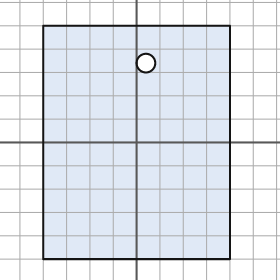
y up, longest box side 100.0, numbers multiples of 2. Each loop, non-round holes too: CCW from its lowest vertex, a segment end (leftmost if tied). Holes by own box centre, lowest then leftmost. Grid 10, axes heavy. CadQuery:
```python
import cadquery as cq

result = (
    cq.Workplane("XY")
    .moveTo(-40.0, -50.0)
    .lineTo(40.0, -50.0)
    .lineTo(40.0, 50.0)
    .lineTo(-40.0, 50.0)
    .close()
    .moveTo(4.0, 34.0)
    .circle(4.0)
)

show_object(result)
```